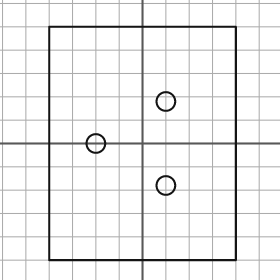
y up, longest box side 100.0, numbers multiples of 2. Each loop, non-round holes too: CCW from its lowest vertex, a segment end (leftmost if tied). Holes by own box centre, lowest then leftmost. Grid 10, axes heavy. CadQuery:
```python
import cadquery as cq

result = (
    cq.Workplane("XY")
    .moveTo(-40.0, -50.0)
    .lineTo(40.0, -50.0)
    .lineTo(40.0, 50.0)
    .lineTo(-40.0, 50.0)
    .close()
    .moveTo(10.0, -18.0)
    .circle(4.0)
    .moveTo(-20.0, 0.0)
    .circle(4.0)
    .moveTo(10.0, 18.0)
    .circle(4.0)
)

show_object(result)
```